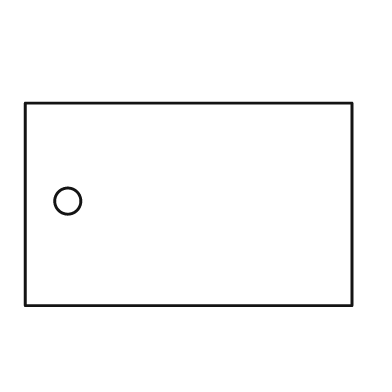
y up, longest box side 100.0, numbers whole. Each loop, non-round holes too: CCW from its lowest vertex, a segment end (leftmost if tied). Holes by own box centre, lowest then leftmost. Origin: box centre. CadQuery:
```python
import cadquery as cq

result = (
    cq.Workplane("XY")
    .moveTo(-50.0, -31.0)
    .lineTo(50.0, -31.0)
    .lineTo(50.0, 31.0)
    .lineTo(-50.0, 31.0)
    .close()
    .moveTo(-37.0, 1.0)
    .circle(4.0)
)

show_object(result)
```